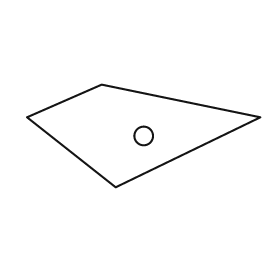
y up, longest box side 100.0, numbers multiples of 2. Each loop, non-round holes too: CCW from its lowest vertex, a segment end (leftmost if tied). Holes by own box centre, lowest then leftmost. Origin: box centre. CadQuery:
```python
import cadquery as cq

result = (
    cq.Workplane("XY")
    .moveTo(-12.0, -22.0)
    .lineTo(50.0, 8.0)
    .lineTo(-18.0, 22.0)
    .lineTo(-50.0, 8.0)
    .close()
    .moveTo(0.0, 0.0)
    .circle(4.0)
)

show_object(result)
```